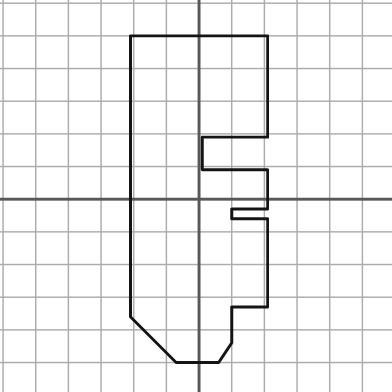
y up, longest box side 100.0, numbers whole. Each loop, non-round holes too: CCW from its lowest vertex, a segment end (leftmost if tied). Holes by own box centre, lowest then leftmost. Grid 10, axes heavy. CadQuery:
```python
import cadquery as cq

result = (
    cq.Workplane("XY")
    .moveTo(-7.0, -50.0)
    .lineTo(6.0, -50.0)
    .lineTo(10.0, -44.0)
    .lineTo(10.0, -33.0)
    .lineTo(21.0, -33.0)
    .lineTo(21.0, -6.0)
    .lineTo(10.0, -6.0)
    .lineTo(10.0, -3.0)
    .lineTo(21.0, -3.0)
    .lineTo(21.0, 9.0)
    .lineTo(1.0, 9.0)
    .lineTo(1.0, 19.0)
    .lineTo(21.0, 19.0)
    .lineTo(21.0, 50.0)
    .lineTo(-21.0, 50.0)
    .lineTo(-21.0, -36.0)
    .close()
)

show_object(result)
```